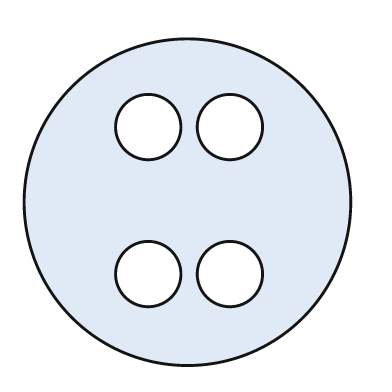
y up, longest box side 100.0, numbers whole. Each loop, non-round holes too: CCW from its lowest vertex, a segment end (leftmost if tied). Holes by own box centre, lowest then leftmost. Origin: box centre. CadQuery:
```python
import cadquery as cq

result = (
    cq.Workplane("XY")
    .moveTo(0.0, 0.0)
    .circle(50.0)
    .moveTo(-12.0, -22.0)
    .circle(10.0)
    .moveTo(13.0, -22.0)
    .circle(10.0)
    .moveTo(-12.0, 23.0)
    .circle(10.0)
    .moveTo(13.0, 23.0)
    .circle(10.0)
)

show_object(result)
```